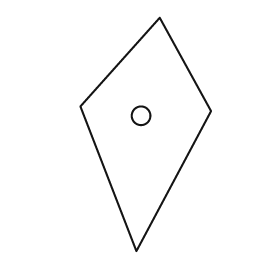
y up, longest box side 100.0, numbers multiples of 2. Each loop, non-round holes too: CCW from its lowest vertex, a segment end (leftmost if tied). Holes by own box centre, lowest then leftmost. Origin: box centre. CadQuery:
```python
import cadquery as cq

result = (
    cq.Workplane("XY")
    .moveTo(-4.0, -50.0)
    .lineTo(28.0, 10.0)
    .lineTo(6.0, 50.0)
    .lineTo(-28.0, 12.0)
    .close()
    .moveTo(-2.0, 8.0)
    .circle(4.0)
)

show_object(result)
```